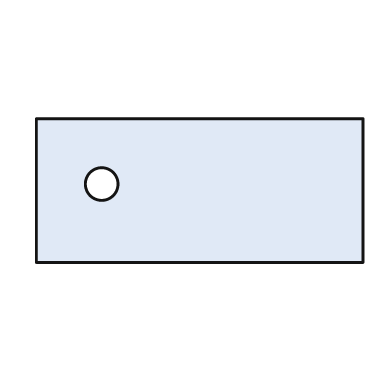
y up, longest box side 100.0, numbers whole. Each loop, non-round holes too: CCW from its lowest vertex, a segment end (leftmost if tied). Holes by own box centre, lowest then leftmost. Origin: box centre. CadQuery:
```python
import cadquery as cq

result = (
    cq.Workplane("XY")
    .moveTo(-50.0, -22.0)
    .lineTo(50.0, -22.0)
    .lineTo(50.0, 22.0)
    .lineTo(-50.0, 22.0)
    .close()
    .moveTo(-30.0, 2.0)
    .circle(5.0)
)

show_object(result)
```